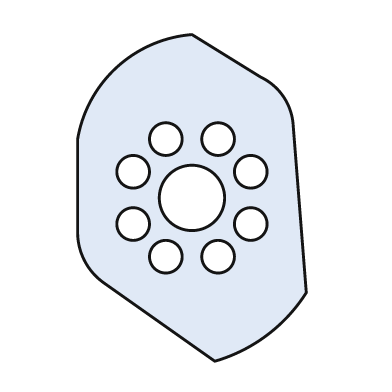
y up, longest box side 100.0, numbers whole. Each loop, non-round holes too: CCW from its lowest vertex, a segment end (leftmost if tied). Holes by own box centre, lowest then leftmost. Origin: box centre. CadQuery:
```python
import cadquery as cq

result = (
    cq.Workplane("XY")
    .moveTo(7.0, -50.0)
    .threePointArc((23.0, -42.0), (35.0, -29.0))
    .lineTo(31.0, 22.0)
    .threePointArc((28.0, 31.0), (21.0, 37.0))
    .lineTo(0.0, 50.0)
    .threePointArc((-23.0, 40.0), (-35.0, 18.0))
    .lineTo(-35.0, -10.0)
    .threePointArc((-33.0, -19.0), (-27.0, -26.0))
    .close()
    .moveTo(-8.0, -18.0)
    .circle(5.0)
    .moveTo(8.0, -18.0)
    .circle(5.0)
    .moveTo(-18.0, -8.0)
    .circle(5.0)
    .moveTo(18.0, -8.0)
    .circle(5.0)
    .moveTo(0.0, 0.0)
    .circle(10.0)
    .moveTo(-18.0, 8.0)
    .circle(5.0)
    .moveTo(18.0, 8.0)
    .circle(5.0)
    .moveTo(-8.0, 18.0)
    .circle(5.0)
    .moveTo(8.0, 18.0)
    .circle(5.0)
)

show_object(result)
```